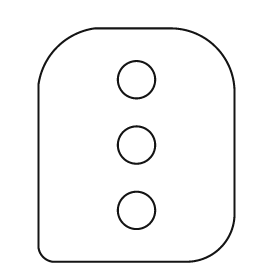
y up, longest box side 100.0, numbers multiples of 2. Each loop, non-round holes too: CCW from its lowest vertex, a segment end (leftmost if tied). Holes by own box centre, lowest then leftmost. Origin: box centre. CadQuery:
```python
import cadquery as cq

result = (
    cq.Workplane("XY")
    .moveTo(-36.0, -50.0)
    .lineTo(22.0, -50.0)
    .threePointArc((36.0, -44.0), (42.0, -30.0))
    .lineTo(42.0, 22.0)
    .threePointArc((34.0, 42.0), (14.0, 50.0))
    .lineTo(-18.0, 50.0)
    .threePointArc((-34.0, 42.0), (-42.0, 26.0))
    .lineTo(-42.0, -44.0)
    .threePointArc((-40.0, -48.0), (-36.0, -50.0))
    .close()
    .moveTo(0.0, -28.0)
    .circle(8.0)
    .moveTo(0.0, 0.0)
    .circle(8.0)
    .moveTo(0.0, 28.0)
    .circle(8.0)
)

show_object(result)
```